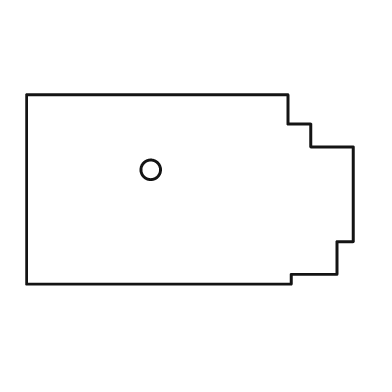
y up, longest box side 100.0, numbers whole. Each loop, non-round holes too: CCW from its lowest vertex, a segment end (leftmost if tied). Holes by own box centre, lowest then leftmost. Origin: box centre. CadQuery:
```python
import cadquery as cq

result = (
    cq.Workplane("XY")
    .moveTo(-50.0, -29.0)
    .lineTo(31.0, -29.0)
    .lineTo(31.0, -26.0)
    .lineTo(45.0, -26.0)
    .lineTo(45.0, -16.0)
    .lineTo(50.0, -16.0)
    .lineTo(50.0, 13.0)
    .lineTo(37.0, 13.0)
    .lineTo(37.0, 20.0)
    .lineTo(30.0, 20.0)
    .lineTo(30.0, 29.0)
    .lineTo(-50.0, 29.0)
    .close()
    .moveTo(-12.0, 6.0)
    .circle(3.0)
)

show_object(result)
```